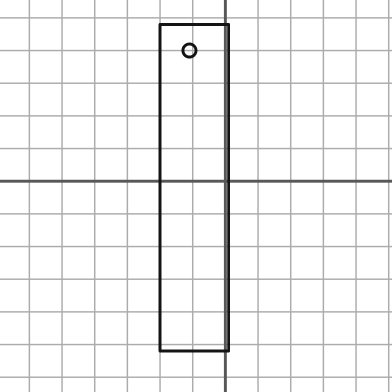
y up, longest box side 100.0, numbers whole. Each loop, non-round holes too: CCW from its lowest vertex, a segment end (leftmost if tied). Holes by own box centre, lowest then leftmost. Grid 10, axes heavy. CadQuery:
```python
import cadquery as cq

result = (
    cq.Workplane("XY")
    .moveTo(-20.0, -52.0)
    .lineTo(1.0, -52.0)
    .lineTo(1.0, 48.0)
    .lineTo(-20.0, 48.0)
    .close()
    .moveTo(-11.0, 40.0)
    .circle(2.0)
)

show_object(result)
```